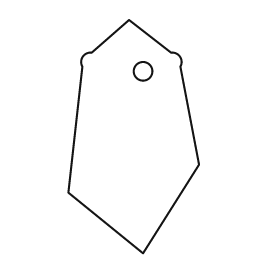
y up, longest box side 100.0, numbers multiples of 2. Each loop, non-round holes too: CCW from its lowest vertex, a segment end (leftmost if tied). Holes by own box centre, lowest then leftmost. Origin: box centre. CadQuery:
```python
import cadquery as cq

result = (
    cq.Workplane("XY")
    .moveTo(4.0, -50.0)
    .lineTo(28.0, -12.0)
    .lineTo(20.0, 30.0)
    .threePointArc((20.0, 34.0), (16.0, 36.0))
    .lineTo(-2.0, 50.0)
    .lineTo(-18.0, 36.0)
    .threePointArc((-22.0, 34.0), (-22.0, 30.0))
    .lineTo(-28.0, -24.0)
    .close()
    .moveTo(4.0, 28.0)
    .circle(4.0)
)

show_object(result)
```